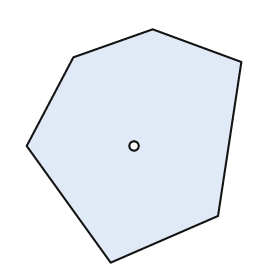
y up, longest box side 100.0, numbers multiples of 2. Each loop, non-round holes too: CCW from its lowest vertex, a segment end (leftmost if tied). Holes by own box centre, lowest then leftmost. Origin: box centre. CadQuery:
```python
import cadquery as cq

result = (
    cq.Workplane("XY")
    .moveTo(-10.0, -50.0)
    .lineTo(36.0, -30.0)
    .lineTo(46.0, 36.0)
    .lineTo(8.0, 50.0)
    .lineTo(-26.0, 38.0)
    .lineTo(-46.0, 0.0)
    .close()
    .moveTo(0.0, 0.0)
    .circle(2.0)
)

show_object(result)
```